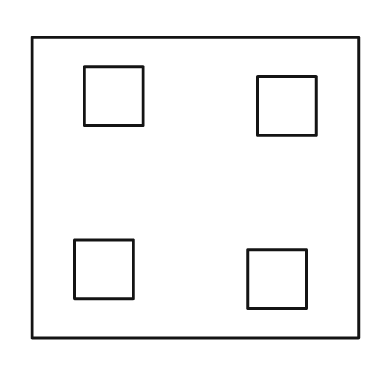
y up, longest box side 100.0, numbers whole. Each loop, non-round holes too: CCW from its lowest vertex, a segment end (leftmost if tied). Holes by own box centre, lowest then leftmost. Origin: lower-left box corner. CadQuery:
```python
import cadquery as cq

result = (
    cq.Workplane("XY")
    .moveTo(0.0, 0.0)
    .lineTo(100.0, 0.0)
    .lineTo(100.0, 92.0)
    .lineTo(0.0, 92.0)
    .close()
    .moveTo(66.0, 9.0)
    .lineTo(84.0, 9.0)
    .lineTo(84.0, 27.0)
    .lineTo(66.0, 27.0)
    .close()
    .moveTo(13.0, 12.0)
    .lineTo(31.0, 12.0)
    .lineTo(31.0, 30.0)
    .lineTo(13.0, 30.0)
    .close()
    .moveTo(69.0, 62.0)
    .lineTo(87.0, 62.0)
    .lineTo(87.0, 80.0)
    .lineTo(69.0, 80.0)
    .close()
    .moveTo(16.0, 65.0)
    .lineTo(34.0, 65.0)
    .lineTo(34.0, 83.0)
    .lineTo(16.0, 83.0)
    .close()
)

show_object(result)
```